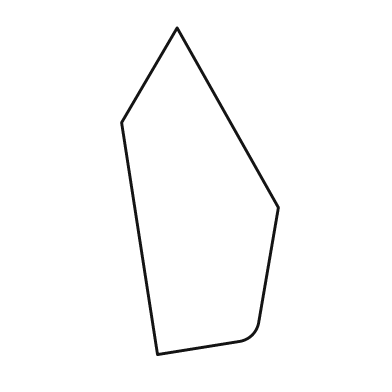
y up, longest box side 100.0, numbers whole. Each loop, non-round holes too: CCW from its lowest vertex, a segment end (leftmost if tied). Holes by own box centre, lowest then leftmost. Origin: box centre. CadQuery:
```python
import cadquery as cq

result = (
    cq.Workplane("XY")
    .moveTo(-13.0, -50.0)
    .lineTo(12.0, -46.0)
    .threePointArc((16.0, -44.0), (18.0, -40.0))
    .lineTo(24.0, -5.0)
    .lineTo(-7.0, 50.0)
    .lineTo(-24.0, 21.0)
    .close()
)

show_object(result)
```